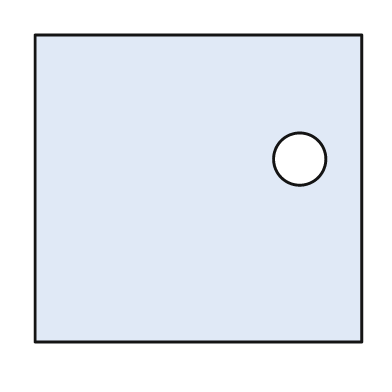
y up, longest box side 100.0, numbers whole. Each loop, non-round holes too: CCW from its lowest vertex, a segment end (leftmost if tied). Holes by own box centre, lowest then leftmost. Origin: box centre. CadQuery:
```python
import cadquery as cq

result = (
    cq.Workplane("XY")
    .moveTo(-50.0, -47.0)
    .lineTo(50.0, -47.0)
    .lineTo(50.0, 47.0)
    .lineTo(-50.0, 47.0)
    .close()
    .moveTo(31.0, 9.0)
    .circle(8.0)
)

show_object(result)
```